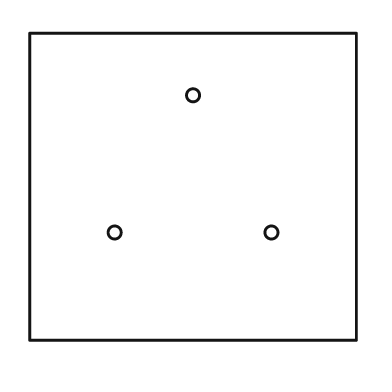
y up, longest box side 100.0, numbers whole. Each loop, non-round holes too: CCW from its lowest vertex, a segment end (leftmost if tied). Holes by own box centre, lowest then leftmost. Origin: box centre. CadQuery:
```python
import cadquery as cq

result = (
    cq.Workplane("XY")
    .moveTo(-50.0, -47.0)
    .lineTo(50.0, -47.0)
    .lineTo(50.0, 47.0)
    .lineTo(-50.0, 47.0)
    .close()
    .moveTo(-24.0, -14.0)
    .circle(2.0)
    .moveTo(24.0, -14.0)
    .circle(2.0)
    .moveTo(0.0, 28.0)
    .circle(2.0)
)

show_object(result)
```